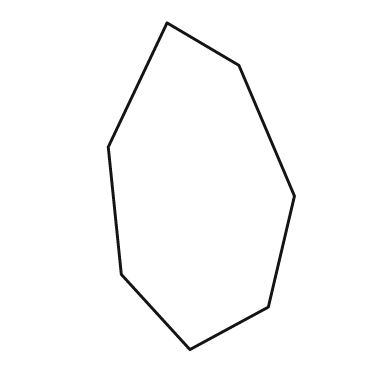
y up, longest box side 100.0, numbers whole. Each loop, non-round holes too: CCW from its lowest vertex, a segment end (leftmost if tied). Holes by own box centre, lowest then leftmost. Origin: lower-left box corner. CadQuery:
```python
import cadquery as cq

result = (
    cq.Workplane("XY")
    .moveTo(25.0, 0.0)
    .lineTo(49.0, 13.0)
    .lineTo(57.0, 47.0)
    .lineTo(40.0, 87.0)
    .lineTo(18.0, 100.0)
    .lineTo(0.0, 62.0)
    .lineTo(4.0, 23.0)
    .close()
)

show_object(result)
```